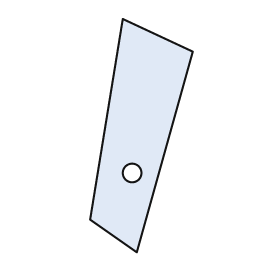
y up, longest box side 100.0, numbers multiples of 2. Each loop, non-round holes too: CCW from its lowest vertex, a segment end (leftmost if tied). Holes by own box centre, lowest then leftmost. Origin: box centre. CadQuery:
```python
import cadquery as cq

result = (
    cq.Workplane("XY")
    .moveTo(-2.0, -50.0)
    .lineTo(22.0, 36.0)
    .lineTo(-8.0, 50.0)
    .lineTo(-22.0, -36.0)
    .close()
    .moveTo(-4.0, -16.0)
    .circle(4.0)
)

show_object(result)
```